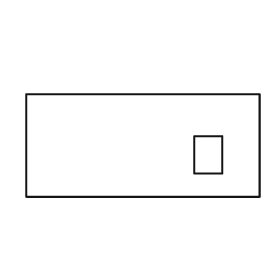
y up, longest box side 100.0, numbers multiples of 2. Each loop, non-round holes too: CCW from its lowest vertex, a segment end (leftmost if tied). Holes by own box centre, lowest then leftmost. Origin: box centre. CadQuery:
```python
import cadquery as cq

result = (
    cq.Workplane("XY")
    .moveTo(-50.0, -22.0)
    .lineTo(50.0, -22.0)
    .lineTo(50.0, 22.0)
    .lineTo(-50.0, 22.0)
    .close()
    .moveTo(22.0, -12.0)
    .lineTo(34.0, -12.0)
    .lineTo(34.0, 4.0)
    .lineTo(22.0, 4.0)
    .close()
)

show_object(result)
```